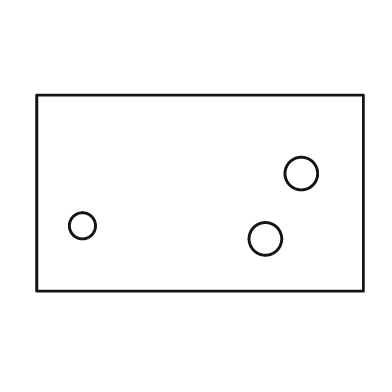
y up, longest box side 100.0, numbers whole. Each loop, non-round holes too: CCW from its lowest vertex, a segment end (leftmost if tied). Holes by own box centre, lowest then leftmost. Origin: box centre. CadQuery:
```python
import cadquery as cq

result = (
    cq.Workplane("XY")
    .moveTo(-50.0, -30.0)
    .lineTo(50.0, -30.0)
    .lineTo(50.0, 30.0)
    .lineTo(-50.0, 30.0)
    .close()
    .moveTo(20.0, -14.0)
    .circle(5.0)
    .moveTo(-36.0, -10.0)
    .circle(4.0)
    .moveTo(31.0, 6.0)
    .circle(5.0)
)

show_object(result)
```